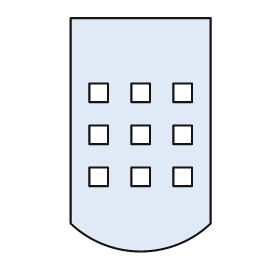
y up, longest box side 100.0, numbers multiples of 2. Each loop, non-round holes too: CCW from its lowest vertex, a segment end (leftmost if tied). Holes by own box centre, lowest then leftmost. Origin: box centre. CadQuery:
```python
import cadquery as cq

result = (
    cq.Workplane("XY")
    .moveTo(-30.0, -38.0)
    .threePointArc((0.0, -50.0), (30.0, -38.0))
    .lineTo(30.0, 50.0)
    .lineTo(-30.0, 50.0)
    .close()
    .moveTo(-22.0, -22.0)
    .lineTo(-14.0, -22.0)
    .lineTo(-14.0, -14.0)
    .lineTo(-22.0, -14.0)
    .close()
    .moveTo(-4.0, -22.0)
    .lineTo(4.0, -22.0)
    .lineTo(4.0, -14.0)
    .lineTo(-4.0, -14.0)
    .close()
    .moveTo(14.0, -22.0)
    .lineTo(22.0, -22.0)
    .lineTo(22.0, -14.0)
    .lineTo(14.0, -14.0)
    .close()
    .moveTo(-22.0, -4.0)
    .lineTo(-14.0, -4.0)
    .lineTo(-14.0, 4.0)
    .lineTo(-22.0, 4.0)
    .close()
    .moveTo(-4.0, -4.0)
    .lineTo(4.0, -4.0)
    .lineTo(4.0, 4.0)
    .lineTo(-4.0, 4.0)
    .close()
    .moveTo(14.0, -4.0)
    .lineTo(22.0, -4.0)
    .lineTo(22.0, 4.0)
    .lineTo(14.0, 4.0)
    .close()
    .moveTo(-22.0, 14.0)
    .lineTo(-14.0, 14.0)
    .lineTo(-14.0, 22.0)
    .lineTo(-22.0, 22.0)
    .close()
    .moveTo(-4.0, 14.0)
    .lineTo(4.0, 14.0)
    .lineTo(4.0, 22.0)
    .lineTo(-4.0, 22.0)
    .close()
    .moveTo(14.0, 14.0)
    .lineTo(22.0, 14.0)
    .lineTo(22.0, 22.0)
    .lineTo(14.0, 22.0)
    .close()
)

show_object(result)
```